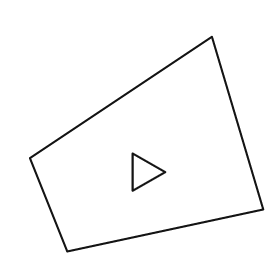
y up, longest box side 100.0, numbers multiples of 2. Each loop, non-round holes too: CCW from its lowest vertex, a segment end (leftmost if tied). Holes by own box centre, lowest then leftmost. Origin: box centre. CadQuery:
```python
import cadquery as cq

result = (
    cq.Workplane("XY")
    .moveTo(-34.0, -46.0)
    .lineTo(50.0, -28.0)
    .lineTo(28.0, 46.0)
    .lineTo(-50.0, -6.0)
    .close()
    .moveTo(-6.0, -20.0)
    .lineTo(8.0, -12.0)
    .lineTo(-6.0, -4.0)
    .close()
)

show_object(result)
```